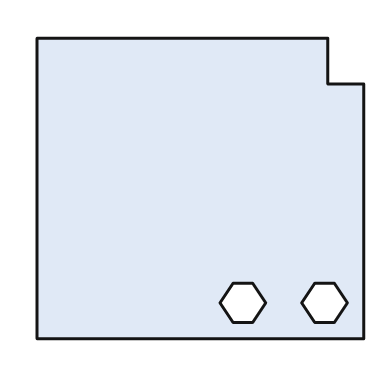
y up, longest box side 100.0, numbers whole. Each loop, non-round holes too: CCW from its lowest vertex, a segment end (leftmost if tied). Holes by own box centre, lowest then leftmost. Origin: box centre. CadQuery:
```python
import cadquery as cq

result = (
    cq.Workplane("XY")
    .moveTo(-50.0, -46.0)
    .lineTo(50.0, -46.0)
    .lineTo(50.0, 32.0)
    .lineTo(39.0, 32.0)
    .lineTo(39.0, 46.0)
    .lineTo(-50.0, 46.0)
    .close()
    .moveTo(10.0, -41.0)
    .lineTo(16.0, -41.0)
    .lineTo(20.0, -35.0)
    .lineTo(16.0, -29.0)
    .lineTo(10.0, -29.0)
    .lineTo(6.0, -35.0)
    .close()
    .moveTo(35.0, -41.0)
    .lineTo(41.0, -41.0)
    .lineTo(45.0, -35.0)
    .lineTo(41.0, -29.0)
    .lineTo(35.0, -29.0)
    .lineTo(31.0, -35.0)
    .close()
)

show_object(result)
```